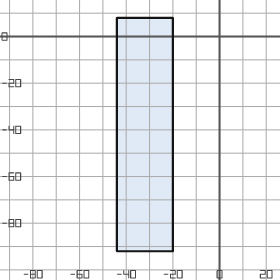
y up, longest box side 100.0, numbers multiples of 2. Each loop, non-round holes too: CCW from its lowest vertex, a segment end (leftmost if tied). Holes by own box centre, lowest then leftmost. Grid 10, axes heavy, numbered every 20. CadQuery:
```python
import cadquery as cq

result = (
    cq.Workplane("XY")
    .moveTo(-44.0, -92.0)
    .lineTo(-20.0, -92.0)
    .lineTo(-20.0, 8.0)
    .lineTo(-44.0, 8.0)
    .close()
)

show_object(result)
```